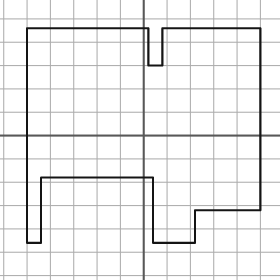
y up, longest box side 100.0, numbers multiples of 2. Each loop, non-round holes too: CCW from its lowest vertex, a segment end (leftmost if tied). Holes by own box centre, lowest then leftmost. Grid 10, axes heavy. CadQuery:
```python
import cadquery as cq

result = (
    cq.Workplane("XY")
    .moveTo(-50.0, -46.0)
    .lineTo(-44.0, -46.0)
    .lineTo(-44.0, -18.0)
    .lineTo(4.0, -18.0)
    .lineTo(4.0, -46.0)
    .lineTo(22.0, -46.0)
    .lineTo(22.0, -32.0)
    .lineTo(50.0, -32.0)
    .lineTo(50.0, 46.0)
    .lineTo(8.0, 46.0)
    .lineTo(8.0, 30.0)
    .lineTo(2.0, 30.0)
    .lineTo(2.0, 46.0)
    .lineTo(-50.0, 46.0)
    .close()
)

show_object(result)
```